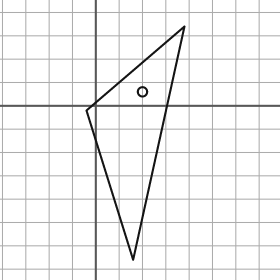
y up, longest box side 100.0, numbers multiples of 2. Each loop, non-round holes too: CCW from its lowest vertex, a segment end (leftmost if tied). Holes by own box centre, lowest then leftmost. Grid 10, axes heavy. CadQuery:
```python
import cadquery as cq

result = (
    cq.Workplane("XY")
    .moveTo(16.0, -66.0)
    .lineTo(38.0, 34.0)
    .lineTo(-4.0, -2.0)
    .close()
    .moveTo(20.0, 6.0)
    .circle(2.0)
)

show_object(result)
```